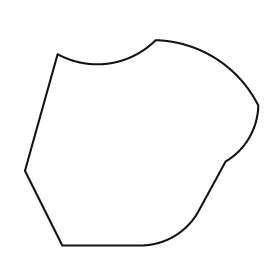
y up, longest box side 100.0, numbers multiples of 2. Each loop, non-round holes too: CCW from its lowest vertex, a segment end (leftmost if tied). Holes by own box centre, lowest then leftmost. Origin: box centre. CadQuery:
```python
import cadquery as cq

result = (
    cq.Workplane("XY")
    .moveTo(-34.0, -44.0)
    .lineTo(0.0, -44.0)
    .threePointArc((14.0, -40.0), (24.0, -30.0))
    .lineTo(36.0, -8.0)
    .threePointArc((46.0, 2.0), (50.0, 16.0))
    .threePointArc((32.0, 36.0), (6.0, 44.0))
    .threePointArc((-14.0, 34.0), (-36.0, 38.0))
    .lineTo(-50.0, -12.0)
    .close()
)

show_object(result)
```